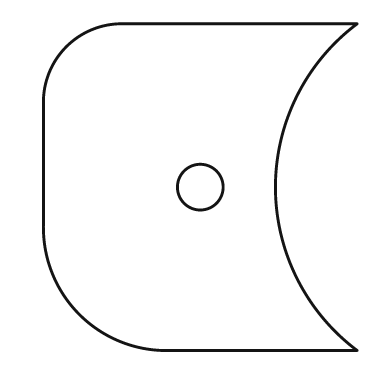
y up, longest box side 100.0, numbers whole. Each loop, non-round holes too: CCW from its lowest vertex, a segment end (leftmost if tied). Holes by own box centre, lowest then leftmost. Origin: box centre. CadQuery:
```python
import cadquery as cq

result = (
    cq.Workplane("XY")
    .moveTo(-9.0, -50.0)
    .lineTo(48.0, -50.0)
    .threePointArc((23.0, 0.0), (48.0, 50.0))
    .lineTo(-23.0, 50.0)
    .threePointArc((-41.0, 43.0), (-48.0, 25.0))
    .lineTo(-48.0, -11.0)
    .threePointArc((-37.0, -39.0), (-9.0, -50.0))
    .close()
    .moveTo(0.0, 0.0)
    .circle(7.0)
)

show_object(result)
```